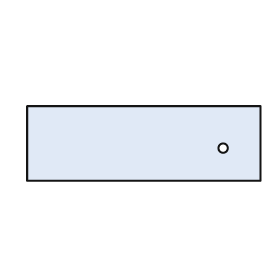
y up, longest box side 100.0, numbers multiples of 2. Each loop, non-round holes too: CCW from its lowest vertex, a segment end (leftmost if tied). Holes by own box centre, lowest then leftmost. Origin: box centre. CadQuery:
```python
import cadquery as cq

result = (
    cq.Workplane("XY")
    .moveTo(-50.0, -16.0)
    .lineTo(50.0, -16.0)
    .lineTo(50.0, 16.0)
    .lineTo(-50.0, 16.0)
    .close()
    .moveTo(34.0, -2.0)
    .circle(2.0)
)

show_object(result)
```